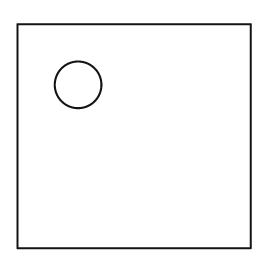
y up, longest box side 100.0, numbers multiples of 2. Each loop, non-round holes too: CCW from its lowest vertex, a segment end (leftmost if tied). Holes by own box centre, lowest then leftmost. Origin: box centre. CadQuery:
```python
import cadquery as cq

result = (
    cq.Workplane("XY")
    .moveTo(-50.0, -48.0)
    .lineTo(50.0, -48.0)
    .lineTo(50.0, 48.0)
    .lineTo(-50.0, 48.0)
    .close()
    .moveTo(-24.0, 22.0)
    .circle(10.0)
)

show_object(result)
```